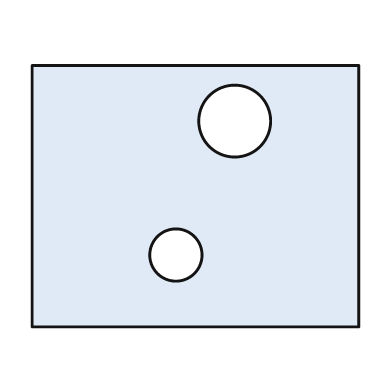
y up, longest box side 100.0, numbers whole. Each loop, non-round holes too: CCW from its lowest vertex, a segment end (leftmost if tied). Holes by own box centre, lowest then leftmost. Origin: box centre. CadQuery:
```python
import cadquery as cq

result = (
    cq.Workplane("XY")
    .moveTo(-50.0, -40.0)
    .lineTo(50.0, -40.0)
    .lineTo(50.0, 40.0)
    .lineTo(-50.0, 40.0)
    .close()
    .moveTo(-6.0, -18.0)
    .circle(8.0)
    .moveTo(12.0, 23.0)
    .circle(11.0)
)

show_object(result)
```